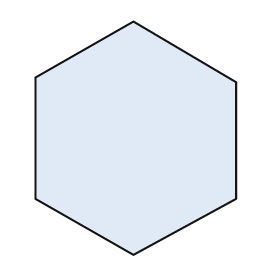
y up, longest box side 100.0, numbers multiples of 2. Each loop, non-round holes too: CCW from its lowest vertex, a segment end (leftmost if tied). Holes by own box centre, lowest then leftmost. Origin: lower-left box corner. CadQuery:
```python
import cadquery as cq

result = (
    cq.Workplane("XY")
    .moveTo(42.0, 0.0)
    .lineTo(86.0, 24.0)
    .lineTo(86.0, 74.0)
    .lineTo(42.0, 100.0)
    .lineTo(0.0, 76.0)
    .lineTo(0.0, 24.0)
    .close()
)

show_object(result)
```